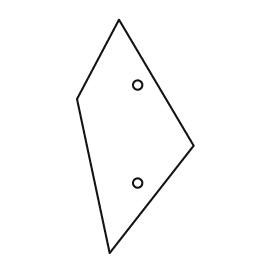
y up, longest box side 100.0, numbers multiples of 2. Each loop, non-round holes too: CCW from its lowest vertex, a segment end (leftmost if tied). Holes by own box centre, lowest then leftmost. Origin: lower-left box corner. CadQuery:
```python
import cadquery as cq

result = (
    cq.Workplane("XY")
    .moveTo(14.0, 0.0)
    .lineTo(50.0, 46.0)
    .lineTo(18.0, 100.0)
    .lineTo(0.0, 66.0)
    .close()
    .moveTo(26.0, 30.0)
    .circle(2.0)
    .moveTo(26.0, 72.0)
    .circle(2.0)
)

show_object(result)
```